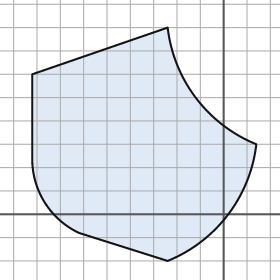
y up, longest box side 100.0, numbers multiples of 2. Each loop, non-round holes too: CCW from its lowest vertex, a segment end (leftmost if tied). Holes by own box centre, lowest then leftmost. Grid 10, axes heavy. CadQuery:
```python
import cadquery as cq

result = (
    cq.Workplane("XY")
    .moveTo(-24.0, -20.0)
    .threePointArc((2.0, 0.0), (14.0, 30.0))
    .threePointArc((-12.0, 50.0), (-24.0, 80.0))
    .lineTo(-82.0, 60.0)
    .lineTo(-82.0, 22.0)
    .threePointArc((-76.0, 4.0), (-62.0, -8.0))
    .close()
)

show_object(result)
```